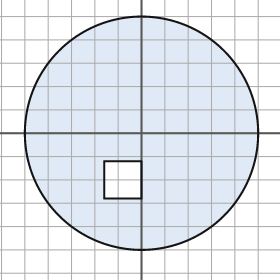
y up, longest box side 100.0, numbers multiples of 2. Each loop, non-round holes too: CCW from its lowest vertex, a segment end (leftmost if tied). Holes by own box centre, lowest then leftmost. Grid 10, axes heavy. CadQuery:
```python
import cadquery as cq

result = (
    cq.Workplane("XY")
    .moveTo(0.0, 0.0)
    .circle(50.0)
    .moveTo(-16.0, -28.0)
    .lineTo(0.0, -28.0)
    .lineTo(0.0, -12.0)
    .lineTo(-16.0, -12.0)
    .close()
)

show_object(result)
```